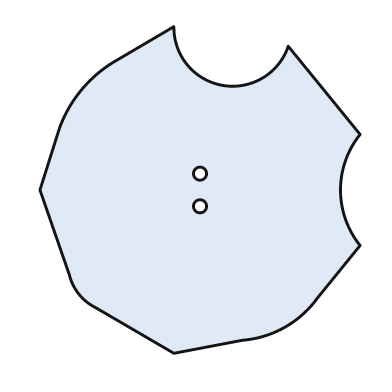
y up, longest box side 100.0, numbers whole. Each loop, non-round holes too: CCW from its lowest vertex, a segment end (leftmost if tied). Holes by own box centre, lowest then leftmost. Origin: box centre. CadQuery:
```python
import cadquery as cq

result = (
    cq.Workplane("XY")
    .moveTo(-8.0, -50.0)
    .lineTo(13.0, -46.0)
    .threePointArc((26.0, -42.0), (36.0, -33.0))
    .lineTo(49.0, -17.0)
    .threePointArc((43.0, 0.0), (49.0, 17.0))
    .lineTo(27.0, 44.0)
    .threePointArc((7.0, 32.0), (-8.0, 50.0))
    .lineTo(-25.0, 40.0)
    .threePointArc((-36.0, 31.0), (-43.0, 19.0))
    .lineTo(-49.0, 0.0)
    .lineTo(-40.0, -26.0)
    .threePointArc((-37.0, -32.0), (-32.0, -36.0))
    .close()
    .moveTo(0.0, -5.0)
    .circle(2.0)
    .moveTo(0.0, 5.0)
    .circle(2.0)
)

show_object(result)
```